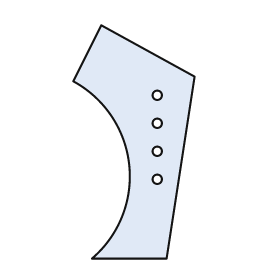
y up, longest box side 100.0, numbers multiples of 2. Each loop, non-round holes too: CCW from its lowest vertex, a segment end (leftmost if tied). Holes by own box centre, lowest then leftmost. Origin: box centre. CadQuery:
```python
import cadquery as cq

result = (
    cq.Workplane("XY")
    .moveTo(-18.0, -50.0)
    .lineTo(14.0, -50.0)
    .lineTo(26.0, 28.0)
    .lineTo(-14.0, 50.0)
    .lineTo(-26.0, 26.0)
    .threePointArc((-2.0, -10.0), (-18.0, -50.0))
    .close()
    .moveTo(10.0, -16.0)
    .circle(2.0)
    .moveTo(10.0, -4.0)
    .circle(2.0)
    .moveTo(10.0, 8.0)
    .circle(2.0)
    .moveTo(10.0, 20.0)
    .circle(2.0)
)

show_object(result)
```